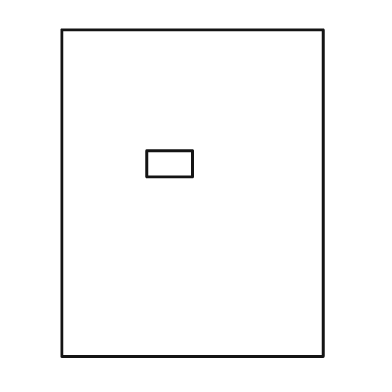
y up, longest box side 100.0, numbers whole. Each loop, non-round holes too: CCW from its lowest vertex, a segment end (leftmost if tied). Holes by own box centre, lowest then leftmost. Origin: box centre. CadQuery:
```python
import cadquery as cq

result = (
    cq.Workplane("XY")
    .moveTo(-40.0, -50.0)
    .lineTo(40.0, -50.0)
    .lineTo(40.0, 50.0)
    .lineTo(-40.0, 50.0)
    .close()
    .moveTo(-14.0, 5.0)
    .lineTo(0.0, 5.0)
    .lineTo(0.0, 13.0)
    .lineTo(-14.0, 13.0)
    .close()
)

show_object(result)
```